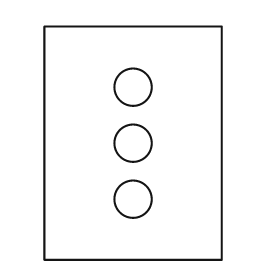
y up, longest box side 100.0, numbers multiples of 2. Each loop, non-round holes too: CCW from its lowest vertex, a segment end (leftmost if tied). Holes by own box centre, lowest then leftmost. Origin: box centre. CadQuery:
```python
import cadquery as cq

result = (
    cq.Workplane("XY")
    .moveTo(-38.0, -50.0)
    .lineTo(38.0, -50.0)
    .lineTo(38.0, 50.0)
    .lineTo(-38.0, 50.0)
    .close()
    .moveTo(0.0, -24.0)
    .circle(8.0)
    .moveTo(0.0, 0.0)
    .circle(8.0)
    .moveTo(0.0, 24.0)
    .circle(8.0)
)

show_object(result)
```